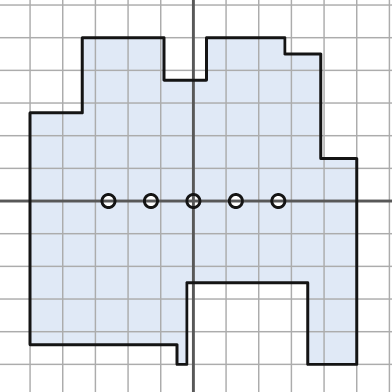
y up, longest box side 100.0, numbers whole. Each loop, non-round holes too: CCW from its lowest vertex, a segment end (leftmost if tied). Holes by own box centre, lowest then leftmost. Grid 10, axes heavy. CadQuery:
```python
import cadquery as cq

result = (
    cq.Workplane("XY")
    .moveTo(-5.0, -50.0)
    .lineTo(-2.0, -50.0)
    .lineTo(-2.0, -25.0)
    .lineTo(35.0, -25.0)
    .lineTo(35.0, -50.0)
    .lineTo(50.0, -50.0)
    .lineTo(50.0, 13.0)
    .lineTo(39.0, 13.0)
    .lineTo(39.0, 45.0)
    .lineTo(28.0, 45.0)
    .lineTo(28.0, 50.0)
    .lineTo(4.0, 50.0)
    .lineTo(4.0, 37.0)
    .lineTo(-9.0, 37.0)
    .lineTo(-9.0, 50.0)
    .lineTo(-34.0, 50.0)
    .lineTo(-34.0, 27.0)
    .lineTo(-50.0, 27.0)
    .lineTo(-50.0, -44.0)
    .lineTo(-5.0, -44.0)
    .close()
    .moveTo(-26.0, 0.0)
    .circle(2.0)
    .moveTo(-13.0, 0.0)
    .circle(2.0)
    .moveTo(0.0, 0.0)
    .circle(2.0)
    .moveTo(13.0, 0.0)
    .circle(2.0)
    .moveTo(26.0, 0.0)
    .circle(2.0)
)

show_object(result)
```